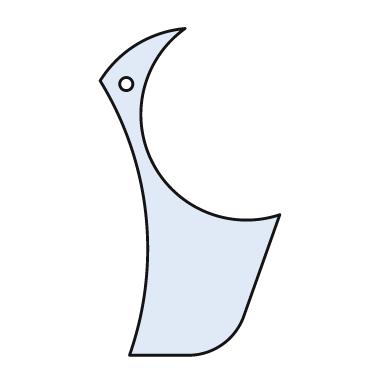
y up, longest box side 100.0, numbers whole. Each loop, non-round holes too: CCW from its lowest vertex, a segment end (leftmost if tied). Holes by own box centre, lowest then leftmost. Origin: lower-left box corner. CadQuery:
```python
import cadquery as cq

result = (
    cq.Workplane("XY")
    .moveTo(9.0, 0.0)
    .lineTo(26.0, 0.0)
    .threePointArc((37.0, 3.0), (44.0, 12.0))
    .lineTo(55.0, 43.0)
    .threePointArc((16.0, 59.0), (26.0, 100.0))
    .threePointArc((11.0, 95.0), (0.0, 84.0))
    .threePointArc((14.0, 43.0), (9.0, 0.0))
    .close()
    .moveTo(8.0, 83.0)
    .circle(2.0)
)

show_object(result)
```